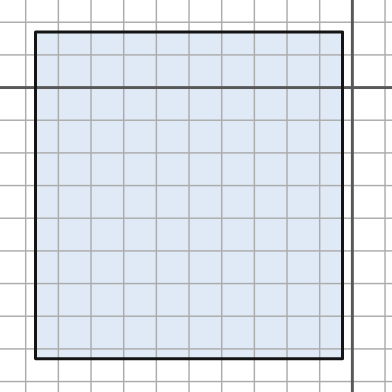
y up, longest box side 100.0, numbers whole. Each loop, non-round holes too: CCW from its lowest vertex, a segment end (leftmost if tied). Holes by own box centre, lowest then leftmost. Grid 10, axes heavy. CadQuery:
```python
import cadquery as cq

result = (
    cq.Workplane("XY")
    .moveTo(-97.0, -83.0)
    .lineTo(-3.0, -83.0)
    .lineTo(-3.0, 17.0)
    .lineTo(-97.0, 17.0)
    .close()
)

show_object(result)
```